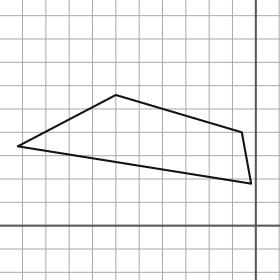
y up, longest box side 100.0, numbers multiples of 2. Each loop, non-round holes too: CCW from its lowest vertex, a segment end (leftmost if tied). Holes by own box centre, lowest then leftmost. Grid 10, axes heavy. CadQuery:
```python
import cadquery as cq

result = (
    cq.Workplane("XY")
    .moveTo(-2.0, 18.0)
    .lineTo(-6.0, 40.0)
    .lineTo(-60.0, 56.0)
    .lineTo(-102.0, 34.0)
    .close()
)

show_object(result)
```